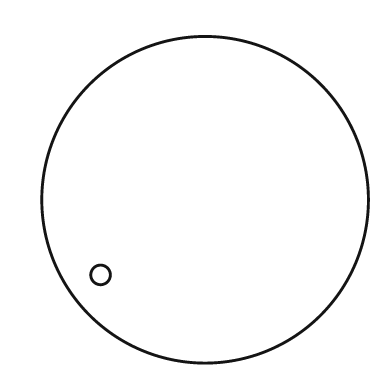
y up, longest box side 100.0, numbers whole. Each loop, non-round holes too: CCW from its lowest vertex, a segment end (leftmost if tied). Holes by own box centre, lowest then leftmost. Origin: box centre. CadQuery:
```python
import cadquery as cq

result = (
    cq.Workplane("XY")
    .moveTo(0.0, 0.0)
    .circle(50.0)
    .moveTo(-32.0, -23.0)
    .circle(3.0)
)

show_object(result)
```